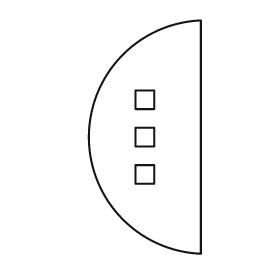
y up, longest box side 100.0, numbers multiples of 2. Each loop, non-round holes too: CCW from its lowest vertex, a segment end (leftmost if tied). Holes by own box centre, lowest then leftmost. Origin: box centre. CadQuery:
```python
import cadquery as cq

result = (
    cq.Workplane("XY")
    .moveTo(24.0, -50.0)
    .lineTo(24.0, 50.0)
    .threePointArc((-24.0, 0.0), (24.0, -50.0))
    .close()
    .moveTo(-4.0, -20.0)
    .lineTo(4.0, -20.0)
    .lineTo(4.0, -12.0)
    .lineTo(-4.0, -12.0)
    .close()
    .moveTo(-4.0, -4.0)
    .lineTo(4.0, -4.0)
    .lineTo(4.0, 4.0)
    .lineTo(-4.0, 4.0)
    .close()
    .moveTo(-4.0, 12.0)
    .lineTo(4.0, 12.0)
    .lineTo(4.0, 20.0)
    .lineTo(-4.0, 20.0)
    .close()
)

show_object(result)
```